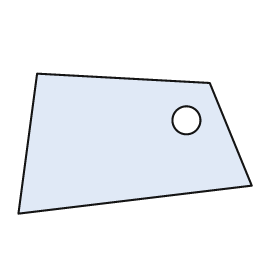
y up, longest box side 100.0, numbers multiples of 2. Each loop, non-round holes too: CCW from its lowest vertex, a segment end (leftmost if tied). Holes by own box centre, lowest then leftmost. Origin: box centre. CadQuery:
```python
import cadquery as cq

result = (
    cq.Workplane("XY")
    .moveTo(-50.0, -30.0)
    .lineTo(50.0, -18.0)
    .lineTo(32.0, 26.0)
    .lineTo(-42.0, 30.0)
    .close()
    .moveTo(22.0, 10.0)
    .circle(6.0)
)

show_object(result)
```